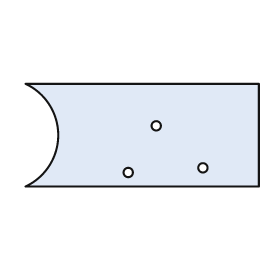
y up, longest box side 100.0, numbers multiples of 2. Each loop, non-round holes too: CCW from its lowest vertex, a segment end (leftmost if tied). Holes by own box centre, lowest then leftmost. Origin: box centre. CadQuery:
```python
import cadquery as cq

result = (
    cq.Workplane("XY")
    .moveTo(-50.0, -22.0)
    .lineTo(50.0, -22.0)
    .lineTo(50.0, 22.0)
    .lineTo(-50.0, 22.0)
    .threePointArc((-36.0, 0.0), (-50.0, -22.0))
    .close()
    .moveTo(-6.0, -16.0)
    .circle(2.0)
    .moveTo(26.0, -14.0)
    .circle(2.0)
    .moveTo(6.0, 4.0)
    .circle(2.0)
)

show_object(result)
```